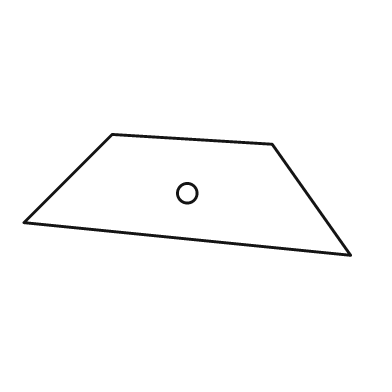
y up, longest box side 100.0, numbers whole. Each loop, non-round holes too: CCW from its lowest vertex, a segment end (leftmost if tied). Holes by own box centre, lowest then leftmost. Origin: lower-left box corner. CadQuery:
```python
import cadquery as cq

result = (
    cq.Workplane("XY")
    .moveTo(100.0, 0.0)
    .lineTo(76.0, 34.0)
    .lineTo(27.0, 37.0)
    .lineTo(0.0, 10.0)
    .close()
    .moveTo(50.0, 19.0)
    .circle(3.0)
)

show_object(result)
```